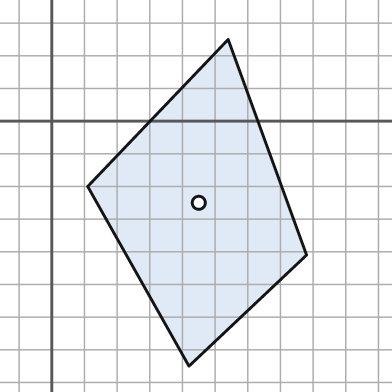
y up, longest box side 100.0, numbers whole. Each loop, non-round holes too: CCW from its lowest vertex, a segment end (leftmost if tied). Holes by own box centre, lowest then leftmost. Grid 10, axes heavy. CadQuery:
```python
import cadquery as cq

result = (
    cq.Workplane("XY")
    .moveTo(42.0, -75.0)
    .lineTo(78.0, -41.0)
    .lineTo(54.0, 25.0)
    .lineTo(11.0, -20.0)
    .close()
    .moveTo(45.0, -25.0)
    .circle(2.0)
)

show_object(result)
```